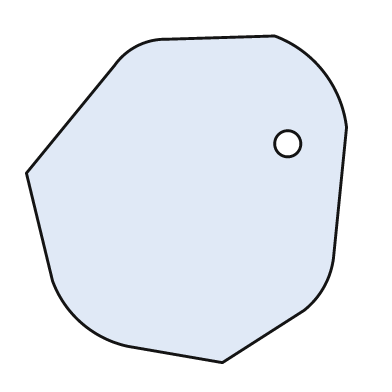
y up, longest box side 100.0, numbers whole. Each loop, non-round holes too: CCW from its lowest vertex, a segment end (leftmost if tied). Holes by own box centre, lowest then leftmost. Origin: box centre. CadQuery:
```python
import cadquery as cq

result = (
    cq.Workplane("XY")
    .moveTo(11.0, -50.0)
    .lineTo(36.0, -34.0)
    .threePointArc((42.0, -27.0), (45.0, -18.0))
    .lineTo(49.0, 22.0)
    .threePointArc((42.0, 39.0), (27.0, 50.0))
    .lineTo(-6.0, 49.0)
    .threePointArc((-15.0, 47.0), (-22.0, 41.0))
    .lineTo(-49.0, 8.0)
    .lineTo(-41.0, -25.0)
    .threePointArc((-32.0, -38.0), (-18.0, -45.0))
    .close()
    .moveTo(31.0, 17.0)
    .circle(4.0)
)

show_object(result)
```